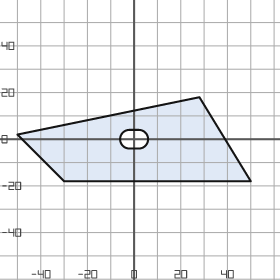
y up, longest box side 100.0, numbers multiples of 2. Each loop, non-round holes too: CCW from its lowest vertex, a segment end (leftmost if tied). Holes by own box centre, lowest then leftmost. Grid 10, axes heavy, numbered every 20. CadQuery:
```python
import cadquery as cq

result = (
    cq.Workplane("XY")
    .moveTo(-30.0, -18.0)
    .lineTo(50.0, -18.0)
    .lineTo(28.0, 18.0)
    .lineTo(-50.0, 2.0)
    .close()
    .moveTo(-2.0, -4.0)
    .lineTo(2.0, -4.0)
    .threePointArc((6.0, 0.0), (2.0, 4.0))
    .lineTo(-2.0, 4.0)
    .threePointArc((-6.0, 0.0), (-2.0, -4.0))
    .close()
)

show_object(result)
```